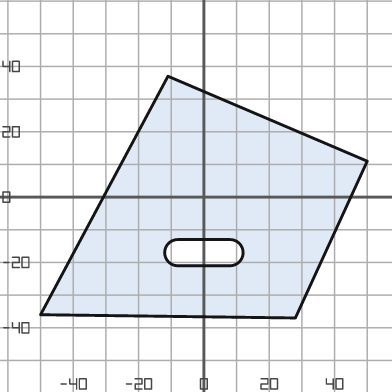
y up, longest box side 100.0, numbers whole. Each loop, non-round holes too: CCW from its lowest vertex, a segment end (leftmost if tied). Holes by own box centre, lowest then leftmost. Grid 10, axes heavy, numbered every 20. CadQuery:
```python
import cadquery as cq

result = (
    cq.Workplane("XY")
    .moveTo(28.0, -37.0)
    .lineTo(50.0, 11.0)
    .lineTo(-11.0, 37.0)
    .lineTo(-50.0, -36.0)
    .close()
    .moveTo(-8.0, -21.0)
    .lineTo(8.0, -21.0)
    .threePointArc((12.0, -17.0), (8.0, -13.0))
    .lineTo(-8.0, -13.0)
    .threePointArc((-12.0, -17.0), (-8.0, -21.0))
    .close()
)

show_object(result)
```